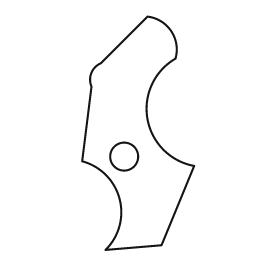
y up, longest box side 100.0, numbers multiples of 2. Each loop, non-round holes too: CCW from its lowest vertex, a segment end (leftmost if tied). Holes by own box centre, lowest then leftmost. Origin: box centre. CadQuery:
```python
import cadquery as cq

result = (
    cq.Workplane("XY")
    .moveTo(-14.0, -50.0)
    .lineTo(10.0, -48.0)
    .lineTo(24.0, -14.0)
    .threePointArc((4.0, 6.0), (16.0, 32.0))
    .threePointArc((14.0, 44.0), (4.0, 50.0))
    .lineTo(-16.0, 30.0)
    .threePointArc((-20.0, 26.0), (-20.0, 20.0))
    .lineTo(-24.0, -12.0)
    .threePointArc((-8.0, -28.0), (-14.0, -50.0))
    .close()
    .moveTo(-6.0, -10.0)
    .circle(6.0)
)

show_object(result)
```